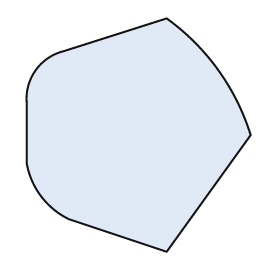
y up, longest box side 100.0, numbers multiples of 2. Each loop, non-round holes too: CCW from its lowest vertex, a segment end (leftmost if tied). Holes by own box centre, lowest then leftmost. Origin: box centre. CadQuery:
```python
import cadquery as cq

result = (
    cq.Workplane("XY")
    .moveTo(12.0, -50.0)
    .lineTo(48.0, 0.0)
    .threePointArc((34.0, 28.0), (12.0, 50.0))
    .lineTo(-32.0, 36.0)
    .threePointArc((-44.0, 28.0), (-48.0, 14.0))
    .lineTo(-48.0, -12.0)
    .threePointArc((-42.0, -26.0), (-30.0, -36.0))
    .close()
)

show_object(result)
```